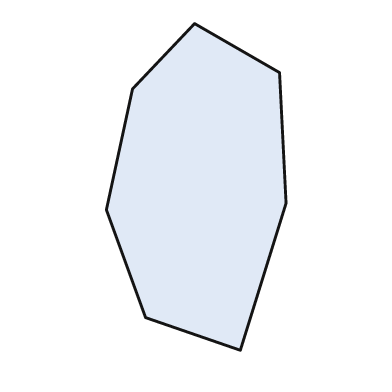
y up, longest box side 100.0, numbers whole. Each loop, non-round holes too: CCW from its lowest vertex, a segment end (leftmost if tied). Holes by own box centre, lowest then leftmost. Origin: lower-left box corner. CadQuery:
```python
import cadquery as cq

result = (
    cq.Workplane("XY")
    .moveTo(41.0, 0.0)
    .lineTo(55.0, 45.0)
    .lineTo(53.0, 85.0)
    .lineTo(27.0, 100.0)
    .lineTo(8.0, 80.0)
    .lineTo(0.0, 43.0)
    .lineTo(12.0, 10.0)
    .close()
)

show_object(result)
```